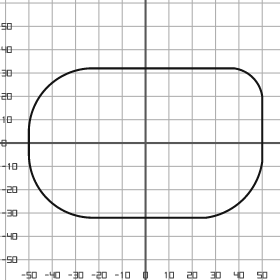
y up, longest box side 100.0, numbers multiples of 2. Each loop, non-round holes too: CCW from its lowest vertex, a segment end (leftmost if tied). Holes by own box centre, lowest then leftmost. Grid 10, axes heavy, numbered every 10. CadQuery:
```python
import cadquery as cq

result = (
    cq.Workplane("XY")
    .moveTo(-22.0, -32.0)
    .lineTo(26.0, -32.0)
    .threePointArc((42.0, -24.0), (50.0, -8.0))
    .lineTo(50.0, 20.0)
    .threePointArc((46.0, 28.0), (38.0, 32.0))
    .lineTo(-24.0, 32.0)
    .threePointArc((-42.0, 24.0), (-50.0, 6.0))
    .lineTo(-50.0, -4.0)
    .threePointArc((-42.0, -24.0), (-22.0, -32.0))
    .close()
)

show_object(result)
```